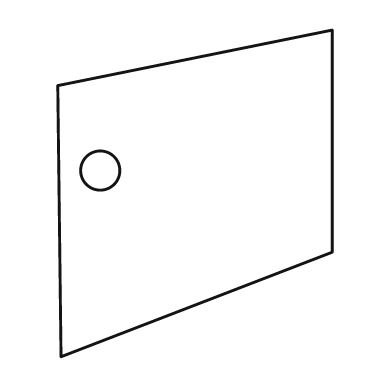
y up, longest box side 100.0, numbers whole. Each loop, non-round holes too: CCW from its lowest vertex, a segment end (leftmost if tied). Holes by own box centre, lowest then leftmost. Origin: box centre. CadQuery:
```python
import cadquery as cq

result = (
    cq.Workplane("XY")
    .moveTo(-41.0, -50.0)
    .lineTo(42.0, -18.0)
    .lineTo(42.0, 50.0)
    .lineTo(-42.0, 33.0)
    .close()
    .moveTo(-29.0, 7.0)
    .circle(6.0)
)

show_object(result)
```